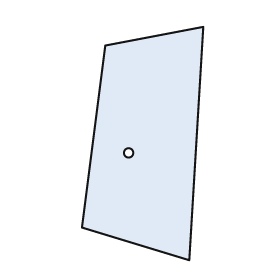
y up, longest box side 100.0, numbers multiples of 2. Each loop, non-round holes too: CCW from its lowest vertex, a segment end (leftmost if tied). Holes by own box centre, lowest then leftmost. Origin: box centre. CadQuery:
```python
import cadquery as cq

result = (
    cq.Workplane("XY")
    .moveTo(20.0, -50.0)
    .lineTo(26.0, 50.0)
    .lineTo(-16.0, 42.0)
    .lineTo(-26.0, -36.0)
    .close()
    .moveTo(-6.0, -4.0)
    .circle(2.0)
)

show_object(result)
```